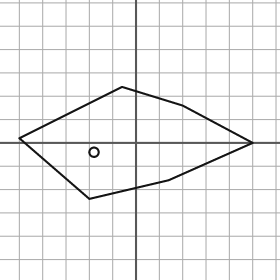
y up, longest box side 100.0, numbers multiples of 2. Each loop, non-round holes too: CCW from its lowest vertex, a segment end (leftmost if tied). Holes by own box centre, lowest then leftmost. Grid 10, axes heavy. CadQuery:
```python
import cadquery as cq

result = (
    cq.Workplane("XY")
    .moveTo(-20.0, -24.0)
    .lineTo(14.0, -16.0)
    .lineTo(50.0, 0.0)
    .lineTo(20.0, 16.0)
    .lineTo(-6.0, 24.0)
    .lineTo(-50.0, 2.0)
    .close()
    .moveTo(-18.0, -4.0)
    .circle(2.0)
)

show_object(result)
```